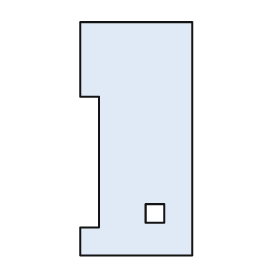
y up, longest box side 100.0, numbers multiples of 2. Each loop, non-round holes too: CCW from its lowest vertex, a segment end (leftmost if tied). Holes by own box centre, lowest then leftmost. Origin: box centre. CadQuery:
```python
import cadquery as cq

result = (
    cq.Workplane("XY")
    .moveTo(-24.0, -50.0)
    .lineTo(24.0, -50.0)
    .lineTo(24.0, 50.0)
    .lineTo(-24.0, 50.0)
    .lineTo(-24.0, 18.0)
    .lineTo(-16.0, 18.0)
    .lineTo(-16.0, -38.0)
    .lineTo(-24.0, -38.0)
    .close()
    .moveTo(4.0, -36.0)
    .lineTo(12.0, -36.0)
    .lineTo(12.0, -28.0)
    .lineTo(4.0, -28.0)
    .close()
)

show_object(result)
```